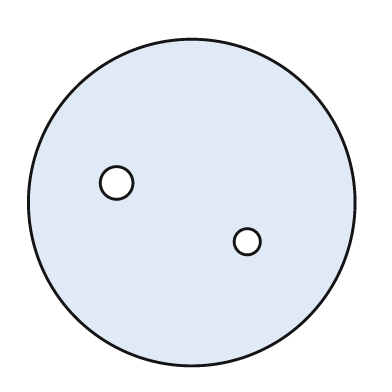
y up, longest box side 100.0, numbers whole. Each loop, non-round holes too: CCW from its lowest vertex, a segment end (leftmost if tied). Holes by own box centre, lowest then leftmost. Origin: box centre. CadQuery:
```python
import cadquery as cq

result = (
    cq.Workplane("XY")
    .moveTo(0.0, 0.0)
    .circle(50.0)
    .moveTo(17.0, -12.0)
    .circle(4.0)
    .moveTo(-23.0, 6.0)
    .circle(5.0)
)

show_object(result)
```